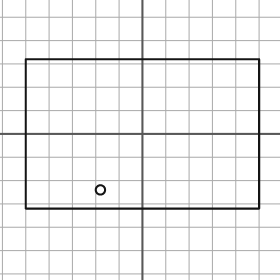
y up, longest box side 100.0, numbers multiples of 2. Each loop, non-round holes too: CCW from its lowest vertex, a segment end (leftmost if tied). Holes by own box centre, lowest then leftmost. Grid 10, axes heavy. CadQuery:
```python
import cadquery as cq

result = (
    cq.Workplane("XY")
    .moveTo(-50.0, -32.0)
    .lineTo(50.0, -32.0)
    .lineTo(50.0, 32.0)
    .lineTo(-50.0, 32.0)
    .close()
    .moveTo(-18.0, -24.0)
    .circle(2.0)
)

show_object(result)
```